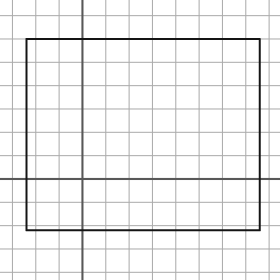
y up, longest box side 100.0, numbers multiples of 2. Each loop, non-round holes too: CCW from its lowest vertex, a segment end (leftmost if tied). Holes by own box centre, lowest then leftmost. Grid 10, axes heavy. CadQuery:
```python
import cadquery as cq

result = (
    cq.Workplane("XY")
    .moveTo(-24.0, -22.0)
    .lineTo(76.0, -22.0)
    .lineTo(76.0, 60.0)
    .lineTo(-24.0, 60.0)
    .close()
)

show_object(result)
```